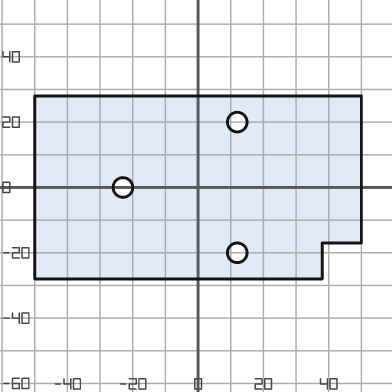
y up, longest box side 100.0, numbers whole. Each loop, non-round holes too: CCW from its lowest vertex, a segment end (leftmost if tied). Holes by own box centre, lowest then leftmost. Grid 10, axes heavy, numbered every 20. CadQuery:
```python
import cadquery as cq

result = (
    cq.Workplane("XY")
    .moveTo(-50.0, -28.0)
    .lineTo(38.0, -28.0)
    .lineTo(38.0, -17.0)
    .lineTo(50.0, -17.0)
    .lineTo(50.0, 28.0)
    .lineTo(-50.0, 28.0)
    .close()
    .moveTo(12.0, -20.0)
    .circle(3.0)
    .moveTo(-23.0, 0.0)
    .circle(3.0)
    .moveTo(12.0, 20.0)
    .circle(3.0)
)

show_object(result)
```